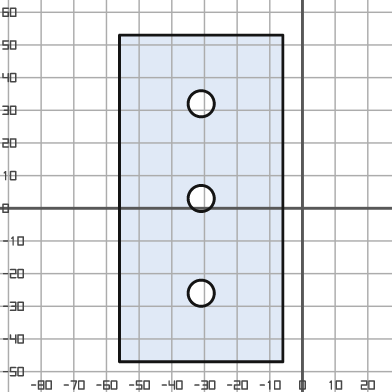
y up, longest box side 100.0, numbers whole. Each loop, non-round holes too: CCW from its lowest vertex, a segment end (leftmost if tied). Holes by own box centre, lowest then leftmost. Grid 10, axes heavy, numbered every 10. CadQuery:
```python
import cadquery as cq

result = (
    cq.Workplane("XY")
    .moveTo(-56.0, -47.0)
    .lineTo(-6.0, -47.0)
    .lineTo(-6.0, 53.0)
    .lineTo(-56.0, 53.0)
    .close()
    .moveTo(-31.0, -26.0)
    .circle(4.0)
    .moveTo(-31.0, 3.0)
    .circle(4.0)
    .moveTo(-31.0, 32.0)
    .circle(4.0)
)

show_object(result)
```